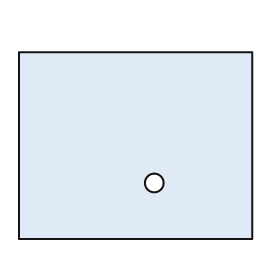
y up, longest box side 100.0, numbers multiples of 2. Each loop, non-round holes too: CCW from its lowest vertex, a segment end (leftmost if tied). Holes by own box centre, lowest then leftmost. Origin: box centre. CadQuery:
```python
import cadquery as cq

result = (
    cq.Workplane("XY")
    .moveTo(-50.0, -40.0)
    .lineTo(50.0, -40.0)
    .lineTo(50.0, 40.0)
    .lineTo(-50.0, 40.0)
    .close()
    .moveTo(8.0, -16.0)
    .circle(4.0)
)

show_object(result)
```